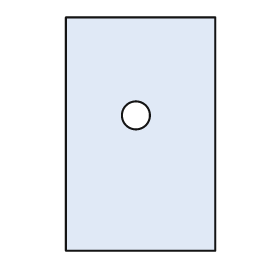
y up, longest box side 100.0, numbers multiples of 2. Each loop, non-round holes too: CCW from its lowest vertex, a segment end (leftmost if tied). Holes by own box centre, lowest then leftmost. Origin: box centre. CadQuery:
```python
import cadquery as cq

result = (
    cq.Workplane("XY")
    .moveTo(-32.0, -50.0)
    .lineTo(32.0, -50.0)
    .lineTo(32.0, 50.0)
    .lineTo(-32.0, 50.0)
    .close()
    .moveTo(-2.0, 8.0)
    .circle(6.0)
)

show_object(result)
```